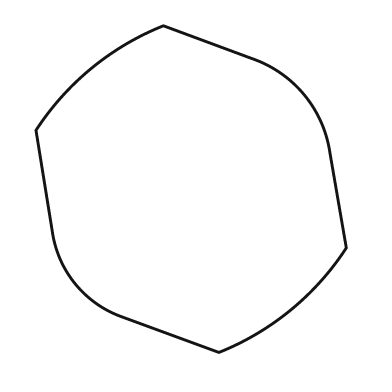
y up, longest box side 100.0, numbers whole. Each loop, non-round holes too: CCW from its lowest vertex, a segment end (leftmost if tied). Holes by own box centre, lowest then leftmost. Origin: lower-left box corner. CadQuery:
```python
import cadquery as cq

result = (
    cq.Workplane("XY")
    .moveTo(56.0, 0.0)
    .threePointArc((78.0, 13.0), (95.0, 32.0))
    .lineTo(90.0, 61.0)
    .threePointArc((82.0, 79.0), (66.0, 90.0))
    .lineTo(39.0, 100.0)
    .threePointArc((17.0, 87.0), (0.0, 68.0))
    .lineTo(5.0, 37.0)
    .threePointArc((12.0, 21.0), (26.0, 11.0))
    .close()
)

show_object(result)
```